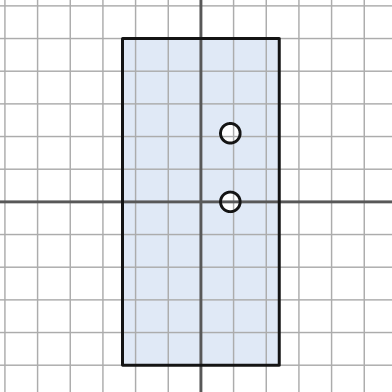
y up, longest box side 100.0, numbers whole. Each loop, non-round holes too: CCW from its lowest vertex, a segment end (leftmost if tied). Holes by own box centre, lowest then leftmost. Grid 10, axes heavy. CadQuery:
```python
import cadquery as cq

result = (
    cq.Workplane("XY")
    .moveTo(-24.0, -50.0)
    .lineTo(24.0, -50.0)
    .lineTo(24.0, 50.0)
    .lineTo(-24.0, 50.0)
    .close()
    .moveTo(9.0, 0.0)
    .circle(3.0)
    .moveTo(9.0, 21.0)
    .circle(3.0)
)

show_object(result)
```